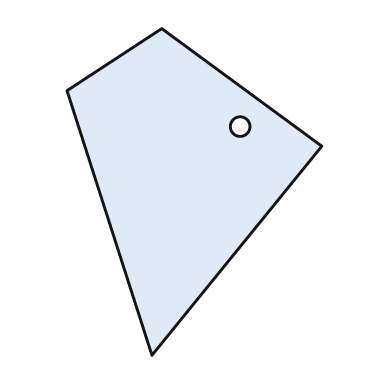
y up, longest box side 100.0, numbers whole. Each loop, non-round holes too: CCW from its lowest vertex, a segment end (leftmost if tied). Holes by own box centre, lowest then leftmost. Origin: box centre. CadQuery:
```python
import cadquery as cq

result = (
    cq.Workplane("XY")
    .moveTo(-13.0, -50.0)
    .lineTo(39.0, 14.0)
    .lineTo(-10.0, 50.0)
    .lineTo(-39.0, 31.0)
    .close()
    .moveTo(14.0, 20.0)
    .circle(3.0)
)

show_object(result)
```